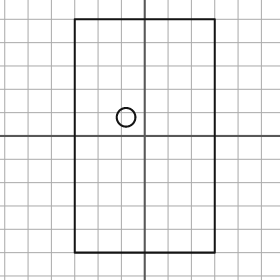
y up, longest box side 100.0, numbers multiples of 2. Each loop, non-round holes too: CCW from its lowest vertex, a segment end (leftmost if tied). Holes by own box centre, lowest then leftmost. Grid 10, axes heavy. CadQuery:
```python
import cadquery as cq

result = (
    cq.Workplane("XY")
    .moveTo(-30.0, -50.0)
    .lineTo(30.0, -50.0)
    .lineTo(30.0, 50.0)
    .lineTo(-30.0, 50.0)
    .close()
    .moveTo(-8.0, 8.0)
    .circle(4.0)
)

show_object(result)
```